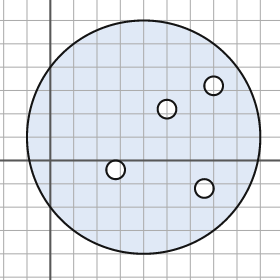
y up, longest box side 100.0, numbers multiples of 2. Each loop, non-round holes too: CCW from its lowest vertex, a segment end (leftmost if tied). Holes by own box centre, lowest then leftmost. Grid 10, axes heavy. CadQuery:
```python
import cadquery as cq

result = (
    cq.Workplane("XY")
    .moveTo(40.0, 10.0)
    .circle(50.0)
    .moveTo(66.0, -12.0)
    .circle(4.0)
    .moveTo(28.0, -4.0)
    .circle(4.0)
    .moveTo(50.0, 22.0)
    .circle(4.0)
    .moveTo(70.0, 32.0)
    .circle(4.0)
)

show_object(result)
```